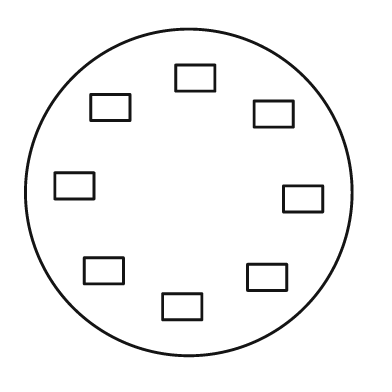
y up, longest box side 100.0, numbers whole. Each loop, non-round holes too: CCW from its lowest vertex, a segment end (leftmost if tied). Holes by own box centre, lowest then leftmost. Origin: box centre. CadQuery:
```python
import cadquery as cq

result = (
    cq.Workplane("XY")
    .moveTo(0.0, 0.0)
    .circle(50.0)
    .moveTo(-8.0, -39.0)
    .lineTo(4.0, -39.0)
    .lineTo(4.0, -31.0)
    .lineTo(-8.0, -31.0)
    .close()
    .moveTo(18.0, -30.0)
    .lineTo(30.0, -30.0)
    .lineTo(30.0, -22.0)
    .lineTo(18.0, -22.0)
    .close()
    .moveTo(-32.0, -28.0)
    .lineTo(-20.0, -28.0)
    .lineTo(-20.0, -20.0)
    .lineTo(-32.0, -20.0)
    .close()
    .moveTo(29.0, -6.0)
    .lineTo(41.0, -6.0)
    .lineTo(41.0, 2.0)
    .lineTo(29.0, 2.0)
    .close()
    .moveTo(-41.0, -2.0)
    .lineTo(-29.0, -2.0)
    .lineTo(-29.0, 6.0)
    .lineTo(-41.0, 6.0)
    .close()
    .moveTo(20.0, 20.0)
    .lineTo(32.0, 20.0)
    .lineTo(32.0, 28.0)
    .lineTo(20.0, 28.0)
    .close()
    .moveTo(-30.0, 22.0)
    .lineTo(-18.0, 22.0)
    .lineTo(-18.0, 30.0)
    .lineTo(-30.0, 30.0)
    .close()
    .moveTo(-4.0, 31.0)
    .lineTo(8.0, 31.0)
    .lineTo(8.0, 39.0)
    .lineTo(-4.0, 39.0)
    .close()
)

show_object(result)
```